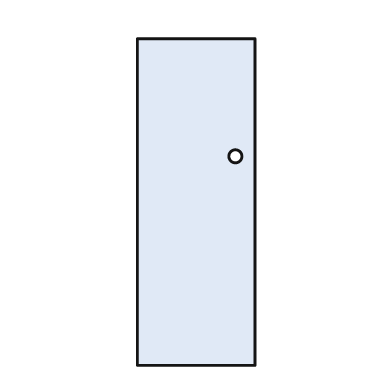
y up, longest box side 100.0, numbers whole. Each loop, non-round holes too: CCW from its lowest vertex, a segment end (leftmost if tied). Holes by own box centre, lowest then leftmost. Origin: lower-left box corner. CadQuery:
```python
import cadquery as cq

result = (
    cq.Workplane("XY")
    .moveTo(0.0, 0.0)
    .lineTo(36.0, 0.0)
    .lineTo(36.0, 100.0)
    .lineTo(0.0, 100.0)
    .close()
    .moveTo(30.0, 64.0)
    .circle(2.0)
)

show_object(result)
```